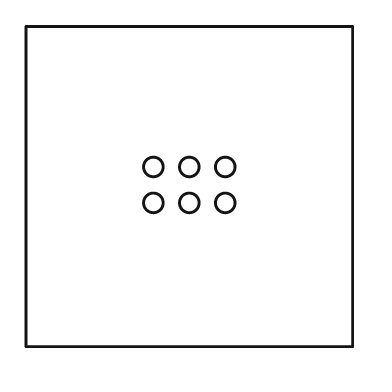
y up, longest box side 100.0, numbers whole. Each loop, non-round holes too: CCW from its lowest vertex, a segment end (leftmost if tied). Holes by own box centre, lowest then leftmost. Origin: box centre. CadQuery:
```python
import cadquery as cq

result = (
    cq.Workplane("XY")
    .moveTo(-50.0, -49.0)
    .lineTo(50.0, -49.0)
    .lineTo(50.0, 49.0)
    .lineTo(-50.0, 49.0)
    .close()
    .moveTo(-11.0, -5.0)
    .circle(3.0)
    .moveTo(0.0, -5.0)
    .circle(3.0)
    .moveTo(11.0, -5.0)
    .circle(3.0)
    .moveTo(-11.0, 6.0)
    .circle(3.0)
    .moveTo(0.0, 6.0)
    .circle(3.0)
    .moveTo(11.0, 6.0)
    .circle(3.0)
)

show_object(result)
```